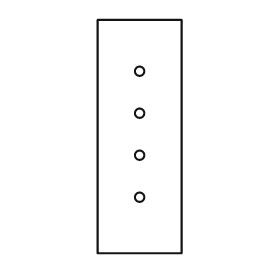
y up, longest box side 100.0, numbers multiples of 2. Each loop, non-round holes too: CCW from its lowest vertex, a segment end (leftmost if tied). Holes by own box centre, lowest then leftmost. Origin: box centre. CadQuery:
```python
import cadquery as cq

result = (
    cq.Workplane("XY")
    .moveTo(-18.0, -50.0)
    .lineTo(18.0, -50.0)
    .lineTo(18.0, 50.0)
    .lineTo(-18.0, 50.0)
    .close()
    .moveTo(0.0, -26.0)
    .circle(2.0)
    .moveTo(0.0, -8.0)
    .circle(2.0)
    .moveTo(0.0, 10.0)
    .circle(2.0)
    .moveTo(0.0, 28.0)
    .circle(2.0)
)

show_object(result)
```